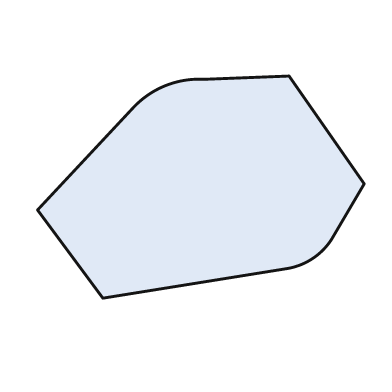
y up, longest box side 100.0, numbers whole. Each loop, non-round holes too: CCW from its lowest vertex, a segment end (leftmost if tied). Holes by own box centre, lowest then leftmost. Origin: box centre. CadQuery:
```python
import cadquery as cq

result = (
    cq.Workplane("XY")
    .moveTo(-30.0, -34.0)
    .lineTo(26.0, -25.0)
    .threePointArc((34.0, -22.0), (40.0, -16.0))
    .lineTo(50.0, 1.0)
    .lineTo(27.0, 34.0)
    .lineTo(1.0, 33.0)
    .threePointArc((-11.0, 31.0), (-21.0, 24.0))
    .lineTo(-50.0, -7.0)
    .close()
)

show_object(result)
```